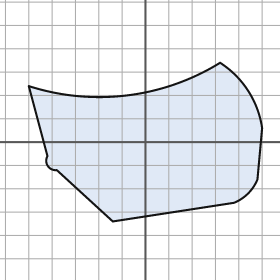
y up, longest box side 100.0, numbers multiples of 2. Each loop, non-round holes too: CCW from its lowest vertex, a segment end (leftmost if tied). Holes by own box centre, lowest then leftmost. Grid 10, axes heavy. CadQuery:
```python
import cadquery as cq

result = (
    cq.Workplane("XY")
    .moveTo(-14.0, -34.0)
    .lineTo(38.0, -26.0)
    .threePointArc((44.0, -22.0), (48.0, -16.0))
    .lineTo(50.0, 6.0)
    .threePointArc((44.0, 22.0), (32.0, 34.0))
    .threePointArc((-8.0, 20.0), (-50.0, 24.0))
    .lineTo(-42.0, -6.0)
    .threePointArc((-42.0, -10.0), (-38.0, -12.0))
    .close()
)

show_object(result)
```